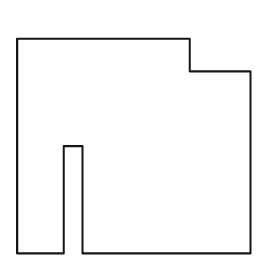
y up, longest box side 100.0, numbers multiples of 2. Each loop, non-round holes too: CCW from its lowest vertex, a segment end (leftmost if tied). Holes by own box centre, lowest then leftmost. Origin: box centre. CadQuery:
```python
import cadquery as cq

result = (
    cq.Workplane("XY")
    .moveTo(-50.0, -46.0)
    .lineTo(-30.0, -46.0)
    .lineTo(-30.0, 0.0)
    .lineTo(-22.0, 0.0)
    .lineTo(-22.0, -46.0)
    .lineTo(50.0, -46.0)
    .lineTo(50.0, 32.0)
    .lineTo(24.0, 32.0)
    .lineTo(24.0, 46.0)
    .lineTo(-50.0, 46.0)
    .close()
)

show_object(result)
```